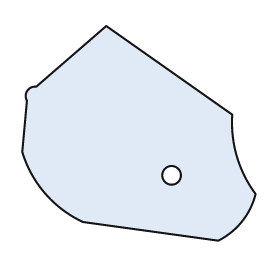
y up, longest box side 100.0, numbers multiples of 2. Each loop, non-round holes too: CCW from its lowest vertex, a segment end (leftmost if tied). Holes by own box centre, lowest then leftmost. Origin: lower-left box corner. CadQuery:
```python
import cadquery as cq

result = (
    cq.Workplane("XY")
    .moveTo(84.0, 0.0)
    .threePointArc((94.0, 8.0), (100.0, 20.0))
    .threePointArc((92.0, 36.0), (90.0, 54.0))
    .lineTo(36.0, 92.0)
    .lineTo(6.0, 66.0)
    .threePointArc((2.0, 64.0), (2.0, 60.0))
    .lineTo(0.0, 38.0)
    .threePointArc((10.0, 20.0), (26.0, 8.0))
    .close()
    .moveTo(64.0, 28.0)
    .circle(4.0)
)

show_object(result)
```